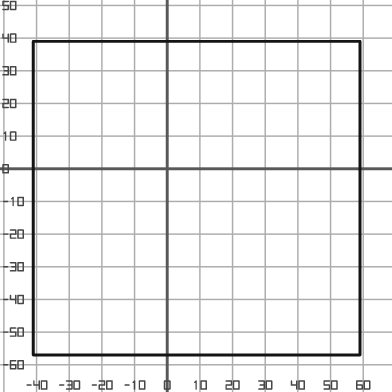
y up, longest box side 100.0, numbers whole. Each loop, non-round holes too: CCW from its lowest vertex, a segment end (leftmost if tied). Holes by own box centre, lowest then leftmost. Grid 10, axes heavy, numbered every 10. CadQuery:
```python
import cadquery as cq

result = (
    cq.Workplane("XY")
    .moveTo(-41.0, -57.0)
    .lineTo(59.0, -57.0)
    .lineTo(59.0, 39.0)
    .lineTo(-41.0, 39.0)
    .close()
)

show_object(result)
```